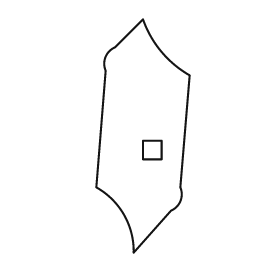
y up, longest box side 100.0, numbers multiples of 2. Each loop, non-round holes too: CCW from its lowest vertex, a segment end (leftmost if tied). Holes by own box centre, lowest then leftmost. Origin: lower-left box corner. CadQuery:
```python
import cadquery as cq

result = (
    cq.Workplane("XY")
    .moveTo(16.0, 0.0)
    .lineTo(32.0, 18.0)
    .threePointArc((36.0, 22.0), (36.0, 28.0))
    .lineTo(40.0, 76.0)
    .threePointArc((28.0, 86.0), (20.0, 100.0))
    .lineTo(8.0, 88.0)
    .threePointArc((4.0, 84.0), (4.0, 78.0))
    .lineTo(0.0, 28.0)
    .threePointArc((12.0, 16.0), (16.0, 0.0))
    .close()
    .moveTo(20.0, 40.0)
    .lineTo(28.0, 40.0)
    .lineTo(28.0, 48.0)
    .lineTo(20.0, 48.0)
    .close()
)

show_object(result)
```